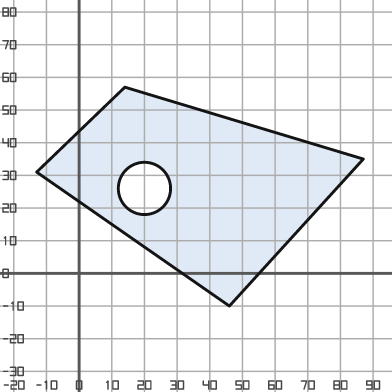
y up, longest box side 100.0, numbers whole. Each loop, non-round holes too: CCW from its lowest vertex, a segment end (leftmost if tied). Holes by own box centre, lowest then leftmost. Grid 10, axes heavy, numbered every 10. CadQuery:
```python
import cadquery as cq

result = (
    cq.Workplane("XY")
    .moveTo(46.0, -10.0)
    .lineTo(87.0, 35.0)
    .lineTo(14.0, 57.0)
    .lineTo(-13.0, 31.0)
    .close()
    .moveTo(20.0, 26.0)
    .circle(8.0)
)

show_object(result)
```